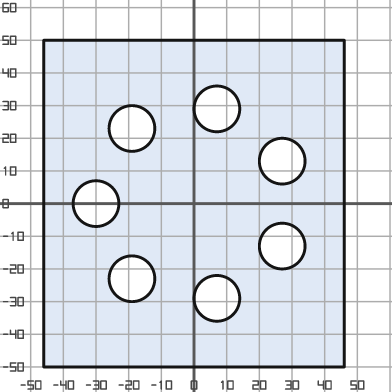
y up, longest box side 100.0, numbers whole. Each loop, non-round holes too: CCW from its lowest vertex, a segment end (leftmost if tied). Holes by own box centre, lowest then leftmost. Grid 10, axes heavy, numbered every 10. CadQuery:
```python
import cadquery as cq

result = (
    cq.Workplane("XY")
    .moveTo(-46.0, -50.0)
    .lineTo(46.0, -50.0)
    .lineTo(46.0, 50.0)
    .lineTo(-46.0, 50.0)
    .close()
    .moveTo(7.0, -29.0)
    .circle(7.0)
    .moveTo(-19.0, -23.0)
    .circle(7.0)
    .moveTo(27.0, -13.0)
    .circle(7.0)
    .moveTo(-30.0, 0.0)
    .circle(7.0)
    .moveTo(27.0, 13.0)
    .circle(7.0)
    .moveTo(-19.0, 23.0)
    .circle(7.0)
    .moveTo(7.0, 29.0)
    .circle(7.0)
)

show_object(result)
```